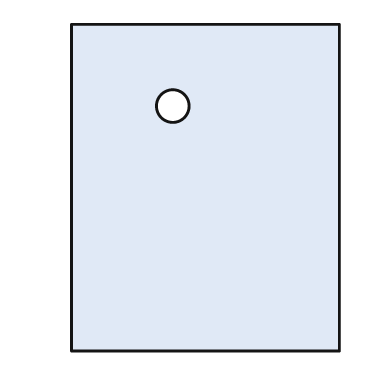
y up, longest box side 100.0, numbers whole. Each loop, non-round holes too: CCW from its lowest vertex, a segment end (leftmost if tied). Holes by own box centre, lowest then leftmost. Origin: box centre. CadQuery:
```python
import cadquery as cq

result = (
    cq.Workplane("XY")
    .moveTo(-41.0, -50.0)
    .lineTo(41.0, -50.0)
    .lineTo(41.0, 50.0)
    .lineTo(-41.0, 50.0)
    .close()
    .moveTo(-10.0, 25.0)
    .circle(5.0)
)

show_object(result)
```